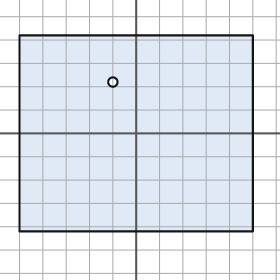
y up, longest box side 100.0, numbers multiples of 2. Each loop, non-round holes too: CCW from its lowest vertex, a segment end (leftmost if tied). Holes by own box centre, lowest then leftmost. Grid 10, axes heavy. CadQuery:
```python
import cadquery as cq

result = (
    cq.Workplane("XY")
    .moveTo(-50.0, -42.0)
    .lineTo(50.0, -42.0)
    .lineTo(50.0, 42.0)
    .lineTo(-50.0, 42.0)
    .close()
    .moveTo(-10.0, 22.0)
    .circle(2.0)
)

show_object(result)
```